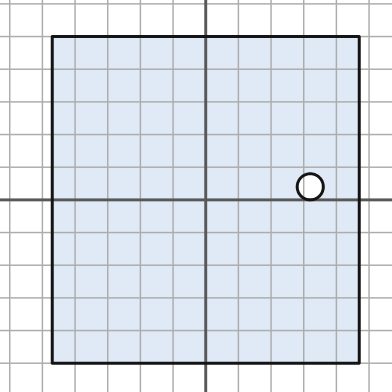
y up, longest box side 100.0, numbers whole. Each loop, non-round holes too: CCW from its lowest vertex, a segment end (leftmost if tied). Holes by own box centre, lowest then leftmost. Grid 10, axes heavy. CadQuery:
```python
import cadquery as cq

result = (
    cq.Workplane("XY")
    .moveTo(-47.0, -50.0)
    .lineTo(47.0, -50.0)
    .lineTo(47.0, 50.0)
    .lineTo(-47.0, 50.0)
    .close()
    .moveTo(32.0, 4.0)
    .circle(4.0)
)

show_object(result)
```